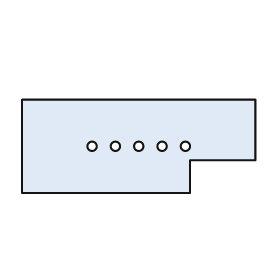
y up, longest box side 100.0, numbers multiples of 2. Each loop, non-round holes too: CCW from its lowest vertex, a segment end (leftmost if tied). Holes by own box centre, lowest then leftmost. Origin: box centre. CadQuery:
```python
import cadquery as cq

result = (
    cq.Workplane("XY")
    .moveTo(-50.0, -20.0)
    .lineTo(22.0, -20.0)
    .lineTo(22.0, -6.0)
    .lineTo(50.0, -6.0)
    .lineTo(50.0, 20.0)
    .lineTo(-50.0, 20.0)
    .close()
    .moveTo(-20.0, 0.0)
    .circle(2.0)
    .moveTo(-10.0, 0.0)
    .circle(2.0)
    .moveTo(0.0, 0.0)
    .circle(2.0)
    .moveTo(10.0, 0.0)
    .circle(2.0)
    .moveTo(20.0, 0.0)
    .circle(2.0)
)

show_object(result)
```